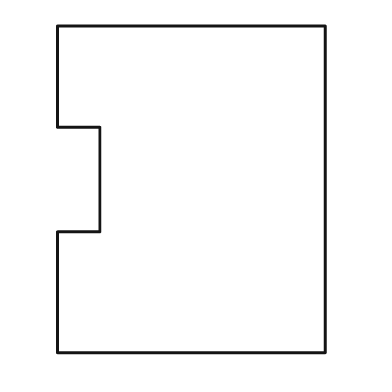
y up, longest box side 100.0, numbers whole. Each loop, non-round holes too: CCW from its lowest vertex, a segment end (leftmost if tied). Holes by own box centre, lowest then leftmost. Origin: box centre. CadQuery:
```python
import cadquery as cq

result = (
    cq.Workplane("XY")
    .moveTo(-41.0, -50.0)
    .lineTo(41.0, -50.0)
    .lineTo(41.0, 50.0)
    .lineTo(-41.0, 50.0)
    .lineTo(-41.0, 19.0)
    .lineTo(-28.0, 19.0)
    .lineTo(-28.0, -13.0)
    .lineTo(-41.0, -13.0)
    .close()
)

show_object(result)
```